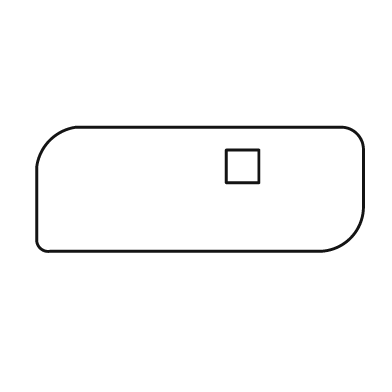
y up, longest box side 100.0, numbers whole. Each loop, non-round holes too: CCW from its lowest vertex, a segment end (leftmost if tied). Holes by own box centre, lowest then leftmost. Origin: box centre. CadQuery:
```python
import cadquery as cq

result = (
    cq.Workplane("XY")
    .moveTo(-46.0, -19.0)
    .lineTo(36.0, -19.0)
    .threePointArc((46.0, -15.0), (50.0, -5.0))
    .lineTo(50.0, 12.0)
    .threePointArc((48.0, 17.0), (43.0, 19.0))
    .lineTo(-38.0, 19.0)
    .threePointArc((-46.0, 15.0), (-50.0, 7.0))
    .lineTo(-50.0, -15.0)
    .threePointArc((-49.0, -18.0), (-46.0, -19.0))
    .close()
    .moveTo(8.0, 2.0)
    .lineTo(18.0, 2.0)
    .lineTo(18.0, 12.0)
    .lineTo(8.0, 12.0)
    .close()
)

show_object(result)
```